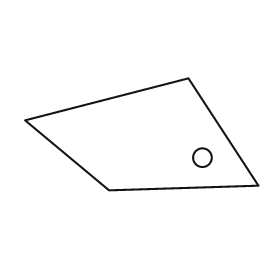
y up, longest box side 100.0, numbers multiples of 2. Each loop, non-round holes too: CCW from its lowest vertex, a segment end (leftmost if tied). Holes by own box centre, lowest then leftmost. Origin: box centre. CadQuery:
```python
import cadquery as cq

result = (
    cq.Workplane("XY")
    .moveTo(-14.0, -24.0)
    .lineTo(50.0, -22.0)
    .lineTo(20.0, 24.0)
    .lineTo(-50.0, 6.0)
    .close()
    .moveTo(26.0, -10.0)
    .circle(4.0)
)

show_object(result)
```